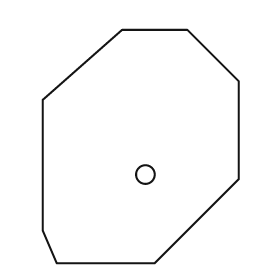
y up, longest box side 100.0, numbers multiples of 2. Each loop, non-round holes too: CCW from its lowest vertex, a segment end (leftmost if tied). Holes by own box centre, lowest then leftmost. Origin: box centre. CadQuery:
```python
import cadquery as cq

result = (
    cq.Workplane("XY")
    .moveTo(-36.0, -50.0)
    .lineTo(6.0, -50.0)
    .lineTo(42.0, -14.0)
    .lineTo(42.0, 28.0)
    .lineTo(20.0, 50.0)
    .lineTo(-8.0, 50.0)
    .lineTo(-42.0, 20.0)
    .lineTo(-42.0, -36.0)
    .close()
    .moveTo(2.0, -12.0)
    .circle(4.0)
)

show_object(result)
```